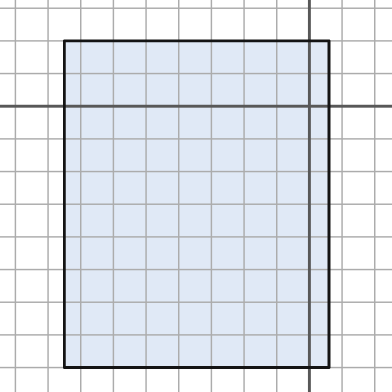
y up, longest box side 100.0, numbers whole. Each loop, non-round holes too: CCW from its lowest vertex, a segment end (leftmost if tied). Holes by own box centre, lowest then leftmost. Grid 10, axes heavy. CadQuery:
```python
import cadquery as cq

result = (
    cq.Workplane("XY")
    .moveTo(-75.0, -80.0)
    .lineTo(6.0, -80.0)
    .lineTo(6.0, 20.0)
    .lineTo(-75.0, 20.0)
    .close()
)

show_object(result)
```